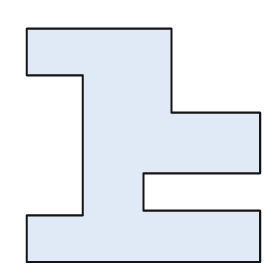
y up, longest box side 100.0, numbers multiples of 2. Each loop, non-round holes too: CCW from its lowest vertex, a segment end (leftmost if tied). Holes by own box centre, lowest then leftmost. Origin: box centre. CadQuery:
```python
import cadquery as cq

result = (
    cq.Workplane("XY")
    .moveTo(-50.0, -50.0)
    .lineTo(50.0, -50.0)
    .lineTo(50.0, -28.0)
    .lineTo(0.0, -28.0)
    .lineTo(0.0, -12.0)
    .lineTo(50.0, -12.0)
    .lineTo(50.0, 14.0)
    .lineTo(12.0, 14.0)
    .lineTo(12.0, 50.0)
    .lineTo(-50.0, 50.0)
    .lineTo(-50.0, 30.0)
    .lineTo(-26.0, 30.0)
    .lineTo(-26.0, -30.0)
    .lineTo(-50.0, -30.0)
    .close()
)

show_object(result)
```